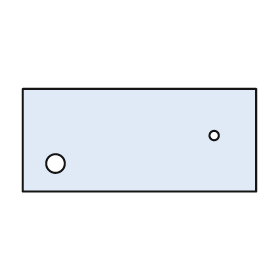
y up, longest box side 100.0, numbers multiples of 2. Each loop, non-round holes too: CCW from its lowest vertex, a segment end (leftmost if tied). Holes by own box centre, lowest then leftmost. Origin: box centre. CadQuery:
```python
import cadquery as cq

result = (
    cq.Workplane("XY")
    .moveTo(-50.0, -22.0)
    .lineTo(50.0, -22.0)
    .lineTo(50.0, 22.0)
    .lineTo(-50.0, 22.0)
    .close()
    .moveTo(-36.0, -10.0)
    .circle(4.0)
    .moveTo(32.0, 2.0)
    .circle(2.0)
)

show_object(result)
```